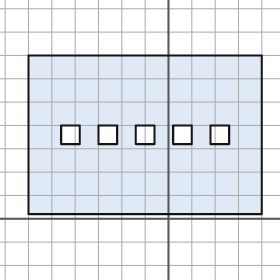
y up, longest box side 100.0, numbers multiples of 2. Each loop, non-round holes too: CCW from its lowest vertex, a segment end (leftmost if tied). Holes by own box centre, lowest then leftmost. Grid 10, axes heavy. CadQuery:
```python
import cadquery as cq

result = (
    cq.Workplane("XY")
    .moveTo(-60.0, 2.0)
    .lineTo(40.0, 2.0)
    .lineTo(40.0, 70.0)
    .lineTo(-60.0, 70.0)
    .close()
    .moveTo(-46.0, 32.0)
    .lineTo(-38.0, 32.0)
    .lineTo(-38.0, 40.0)
    .lineTo(-46.0, 40.0)
    .close()
    .moveTo(-30.0, 32.0)
    .lineTo(-22.0, 32.0)
    .lineTo(-22.0, 40.0)
    .lineTo(-30.0, 40.0)
    .close()
    .moveTo(-14.0, 32.0)
    .lineTo(-6.0, 32.0)
    .lineTo(-6.0, 40.0)
    .lineTo(-14.0, 40.0)
    .close()
    .moveTo(2.0, 32.0)
    .lineTo(10.0, 32.0)
    .lineTo(10.0, 40.0)
    .lineTo(2.0, 40.0)
    .close()
    .moveTo(18.0, 32.0)
    .lineTo(26.0, 32.0)
    .lineTo(26.0, 40.0)
    .lineTo(18.0, 40.0)
    .close()
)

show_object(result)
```